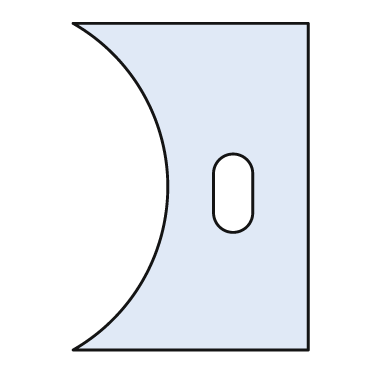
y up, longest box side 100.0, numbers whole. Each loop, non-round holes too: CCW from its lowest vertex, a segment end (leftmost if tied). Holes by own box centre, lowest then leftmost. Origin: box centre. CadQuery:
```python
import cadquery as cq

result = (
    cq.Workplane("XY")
    .moveTo(-36.0, -50.0)
    .lineTo(36.0, -50.0)
    .lineTo(36.0, 50.0)
    .lineTo(-36.0, 50.0)
    .threePointArc((-7.0, 0.0), (-36.0, -50.0))
    .close()
    .moveTo(7.0, -8.0)
    .threePointArc((13.0, -14.0), (19.0, -8.0))
    .lineTo(19.0, 4.0)
    .threePointArc((13.0, 10.0), (7.0, 4.0))
    .close()
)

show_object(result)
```